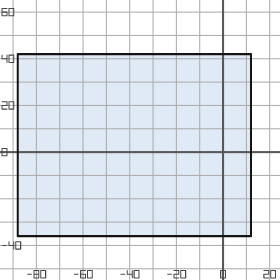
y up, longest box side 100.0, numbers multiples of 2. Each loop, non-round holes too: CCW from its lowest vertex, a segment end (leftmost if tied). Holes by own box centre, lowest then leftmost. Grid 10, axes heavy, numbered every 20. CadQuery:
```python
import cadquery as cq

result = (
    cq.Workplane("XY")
    .moveTo(-88.0, -36.0)
    .lineTo(12.0, -36.0)
    .lineTo(12.0, 42.0)
    .lineTo(-88.0, 42.0)
    .close()
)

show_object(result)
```